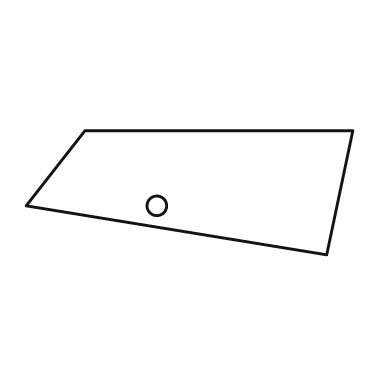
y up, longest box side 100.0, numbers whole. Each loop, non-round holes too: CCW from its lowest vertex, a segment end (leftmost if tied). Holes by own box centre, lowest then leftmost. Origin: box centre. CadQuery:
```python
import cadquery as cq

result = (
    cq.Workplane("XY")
    .moveTo(42.0, -19.0)
    .lineTo(50.0, 19.0)
    .lineTo(-32.0, 19.0)
    .lineTo(-50.0, -4.0)
    .close()
    .moveTo(-10.0, -4.0)
    .circle(3.0)
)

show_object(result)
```